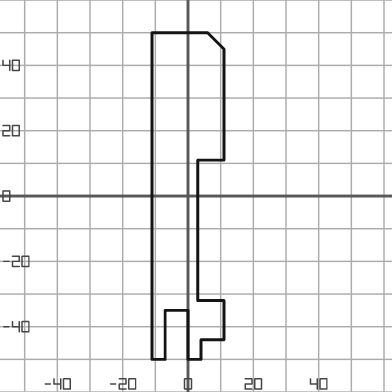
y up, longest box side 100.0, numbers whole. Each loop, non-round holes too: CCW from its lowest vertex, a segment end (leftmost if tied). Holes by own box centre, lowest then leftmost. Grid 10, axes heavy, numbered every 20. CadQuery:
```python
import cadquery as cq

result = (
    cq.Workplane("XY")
    .moveTo(-11.0, -50.0)
    .lineTo(-7.0, -50.0)
    .lineTo(-7.0, -35.0)
    .lineTo(0.0, -35.0)
    .lineTo(0.0, -50.0)
    .lineTo(4.0, -50.0)
    .lineTo(4.0, -44.0)
    .lineTo(11.0, -44.0)
    .lineTo(11.0, -32.0)
    .lineTo(3.0, -32.0)
    .lineTo(3.0, 11.0)
    .lineTo(11.0, 11.0)
    .lineTo(11.0, 45.0)
    .lineTo(6.0, 50.0)
    .lineTo(-11.0, 50.0)
    .close()
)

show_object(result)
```